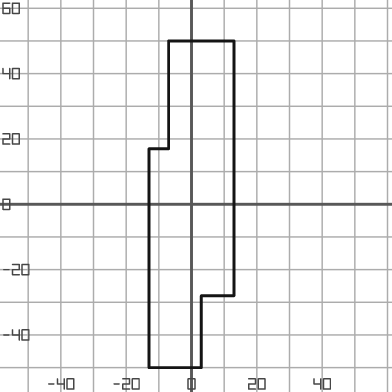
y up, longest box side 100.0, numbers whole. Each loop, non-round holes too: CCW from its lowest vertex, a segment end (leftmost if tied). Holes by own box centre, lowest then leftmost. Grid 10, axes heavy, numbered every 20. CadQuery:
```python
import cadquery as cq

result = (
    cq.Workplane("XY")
    .moveTo(-13.0, -50.0)
    .lineTo(3.0, -50.0)
    .lineTo(3.0, -28.0)
    .lineTo(13.0, -28.0)
    .lineTo(13.0, 50.0)
    .lineTo(-7.0, 50.0)
    .lineTo(-7.0, 17.0)
    .lineTo(-13.0, 17.0)
    .close()
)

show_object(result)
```